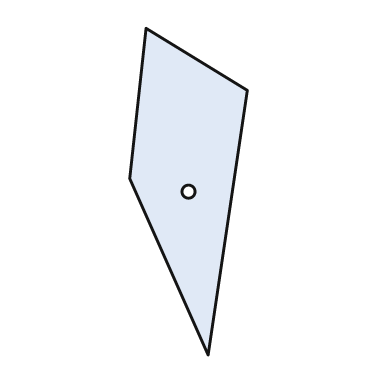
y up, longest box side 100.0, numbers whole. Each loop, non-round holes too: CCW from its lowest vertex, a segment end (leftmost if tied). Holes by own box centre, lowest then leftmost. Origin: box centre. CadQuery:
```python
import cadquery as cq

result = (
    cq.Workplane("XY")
    .moveTo(6.0, -50.0)
    .lineTo(18.0, 31.0)
    .lineTo(-13.0, 50.0)
    .lineTo(-18.0, 4.0)
    .close()
    .moveTo(0.0, 0.0)
    .circle(2.0)
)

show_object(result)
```